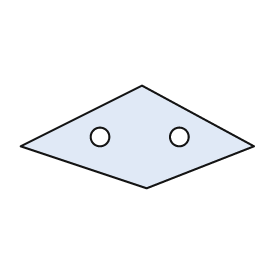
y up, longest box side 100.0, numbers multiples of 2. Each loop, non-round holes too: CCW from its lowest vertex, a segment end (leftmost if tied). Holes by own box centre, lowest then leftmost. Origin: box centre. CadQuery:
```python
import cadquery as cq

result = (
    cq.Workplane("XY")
    .moveTo(4.0, -22.0)
    .lineTo(50.0, -4.0)
    .lineTo(2.0, 22.0)
    .lineTo(-50.0, -4.0)
    .close()
    .moveTo(-16.0, 0.0)
    .circle(4.0)
    .moveTo(18.0, 0.0)
    .circle(4.0)
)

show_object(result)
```